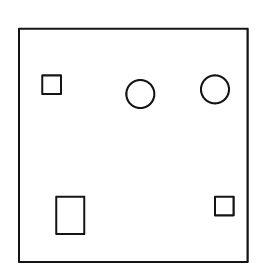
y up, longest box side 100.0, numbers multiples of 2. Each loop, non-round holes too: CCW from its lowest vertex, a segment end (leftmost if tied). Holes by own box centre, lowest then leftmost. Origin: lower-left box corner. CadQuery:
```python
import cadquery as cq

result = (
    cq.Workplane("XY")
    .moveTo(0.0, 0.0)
    .lineTo(98.0, 0.0)
    .lineTo(98.0, 100.0)
    .lineTo(0.0, 100.0)
    .close()
    .moveTo(16.0, 12.0)
    .lineTo(28.0, 12.0)
    .lineTo(28.0, 28.0)
    .lineTo(16.0, 28.0)
    .close()
    .moveTo(84.0, 20.0)
    .lineTo(92.0, 20.0)
    .lineTo(92.0, 28.0)
    .lineTo(84.0, 28.0)
    .close()
    .moveTo(52.0, 72.0)
    .circle(6.0)
    .moveTo(84.0, 74.0)
    .circle(6.0)
    .moveTo(10.0, 72.0)
    .lineTo(18.0, 72.0)
    .lineTo(18.0, 80.0)
    .lineTo(10.0, 80.0)
    .close()
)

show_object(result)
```